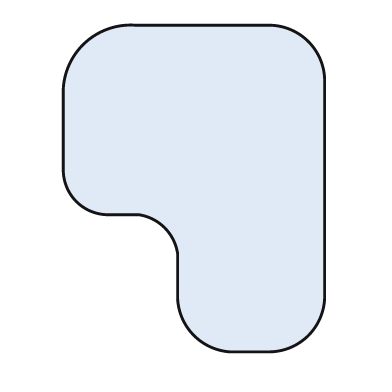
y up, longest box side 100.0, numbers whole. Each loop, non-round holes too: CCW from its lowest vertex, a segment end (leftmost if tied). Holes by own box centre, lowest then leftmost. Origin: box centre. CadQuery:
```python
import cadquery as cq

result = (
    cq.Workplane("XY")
    .moveTo(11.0, -50.0)
    .lineTo(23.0, -50.0)
    .threePointArc((35.0, -45.0), (40.0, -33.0))
    .lineTo(40.0, 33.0)
    .threePointArc((35.0, 45.0), (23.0, 50.0))
    .lineTo(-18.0, 50.0)
    .threePointArc((-34.0, 44.0), (-40.0, 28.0))
    .lineTo(-40.0, 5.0)
    .threePointArc((-36.0, -4.0), (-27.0, -8.0))
    .lineTo(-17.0, -8.0)
    .threePointArc((-9.0, -12.0), (-5.0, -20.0))
    .lineTo(-5.0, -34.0)
    .threePointArc((0.0, -45.0), (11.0, -50.0))
    .close()
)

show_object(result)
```